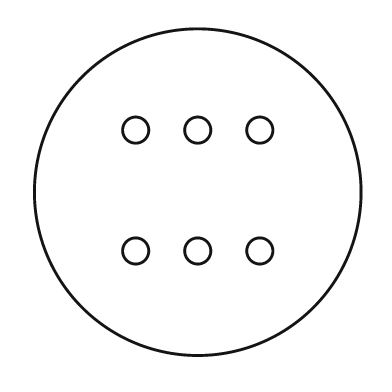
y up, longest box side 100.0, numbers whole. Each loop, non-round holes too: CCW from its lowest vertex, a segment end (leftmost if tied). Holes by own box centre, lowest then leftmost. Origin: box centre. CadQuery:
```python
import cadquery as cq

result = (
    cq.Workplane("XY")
    .moveTo(0.0, 0.0)
    .circle(50.0)
    .moveTo(-19.0, -18.0)
    .circle(4.0)
    .moveTo(0.0, -18.0)
    .circle(4.0)
    .moveTo(19.0, -18.0)
    .circle(4.0)
    .moveTo(-19.0, 19.0)
    .circle(4.0)
    .moveTo(0.0, 19.0)
    .circle(4.0)
    .moveTo(19.0, 19.0)
    .circle(4.0)
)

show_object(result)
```